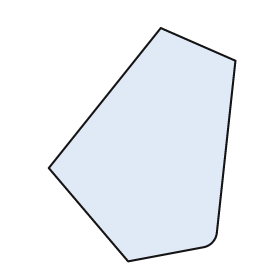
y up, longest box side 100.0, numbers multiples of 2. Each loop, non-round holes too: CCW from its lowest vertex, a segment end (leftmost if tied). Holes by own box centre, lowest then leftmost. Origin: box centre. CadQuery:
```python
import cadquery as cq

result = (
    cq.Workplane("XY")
    .moveTo(-6.0, -50.0)
    .lineTo(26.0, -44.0)
    .threePointArc((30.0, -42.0), (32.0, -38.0))
    .lineTo(40.0, 36.0)
    .lineTo(8.0, 50.0)
    .lineTo(-40.0, -10.0)
    .close()
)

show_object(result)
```